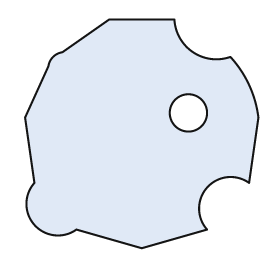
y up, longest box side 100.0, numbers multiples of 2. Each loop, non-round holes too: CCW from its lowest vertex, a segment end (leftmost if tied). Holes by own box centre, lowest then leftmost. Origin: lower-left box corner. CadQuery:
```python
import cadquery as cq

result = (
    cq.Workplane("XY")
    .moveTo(50.0, 0.0)
    .lineTo(78.0, 8.0)
    .threePointArc((78.0, 26.0), (96.0, 28.0))
    .lineTo(100.0, 56.0)
    .threePointArc((96.0, 70.0), (88.0, 82.0))
    .threePointArc((72.0, 84.0), (64.0, 98.0))
    .lineTo(36.0, 98.0)
    .lineTo(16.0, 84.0)
    .threePointArc((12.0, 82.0), (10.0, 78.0))
    .lineTo(0.0, 56.0)
    .lineTo(4.0, 28.0)
    .threePointArc((4.0, 10.0), (22.0, 8.0))
    .close()
    .moveTo(70.0, 58.0)
    .circle(8.0)
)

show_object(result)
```